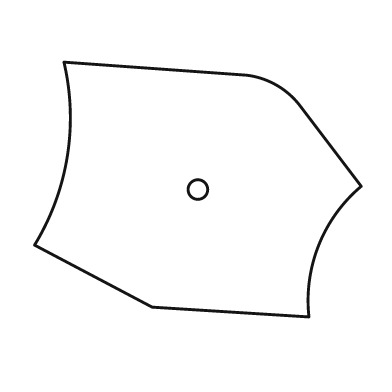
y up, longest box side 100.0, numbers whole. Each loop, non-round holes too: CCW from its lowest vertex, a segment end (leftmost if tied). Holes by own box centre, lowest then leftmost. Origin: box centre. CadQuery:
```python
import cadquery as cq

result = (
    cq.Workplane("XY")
    .moveTo(34.0, -39.0)
    .threePointArc((37.0, -17.0), (50.0, 1.0))
    .lineTo(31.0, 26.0)
    .threePointArc((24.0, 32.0), (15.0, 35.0))
    .lineTo(-41.0, 39.0)
    .threePointArc((-40.0, 10.0), (-50.0, -17.0))
    .lineTo(-14.0, -36.0)
    .close()
    .moveTo(0.0, 0.0)
    .circle(3.0)
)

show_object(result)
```